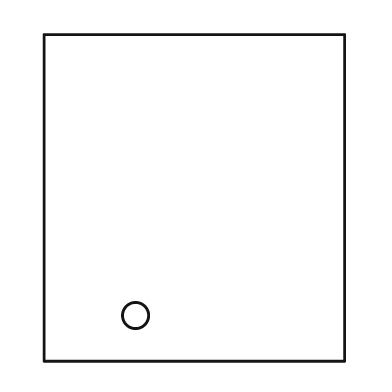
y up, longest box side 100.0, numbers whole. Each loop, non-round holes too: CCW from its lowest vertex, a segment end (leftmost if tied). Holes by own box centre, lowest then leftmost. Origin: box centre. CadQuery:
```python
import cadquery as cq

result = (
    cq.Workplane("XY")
    .moveTo(-46.0, -50.0)
    .lineTo(46.0, -50.0)
    .lineTo(46.0, 50.0)
    .lineTo(-46.0, 50.0)
    .close()
    .moveTo(-18.0, -36.0)
    .circle(4.0)
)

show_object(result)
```